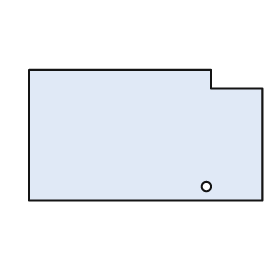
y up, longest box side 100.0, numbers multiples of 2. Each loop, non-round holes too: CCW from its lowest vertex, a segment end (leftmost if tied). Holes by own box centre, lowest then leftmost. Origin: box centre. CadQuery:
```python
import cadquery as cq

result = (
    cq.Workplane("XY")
    .moveTo(-50.0, -28.0)
    .lineTo(50.0, -28.0)
    .lineTo(50.0, 20.0)
    .lineTo(28.0, 20.0)
    .lineTo(28.0, 28.0)
    .lineTo(-50.0, 28.0)
    .close()
    .moveTo(26.0, -22.0)
    .circle(2.0)
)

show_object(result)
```